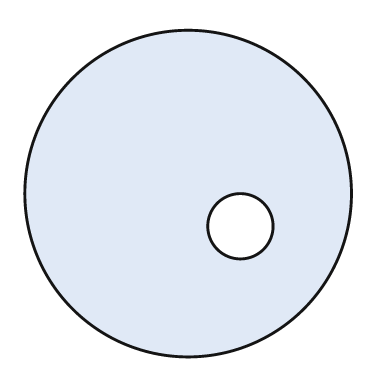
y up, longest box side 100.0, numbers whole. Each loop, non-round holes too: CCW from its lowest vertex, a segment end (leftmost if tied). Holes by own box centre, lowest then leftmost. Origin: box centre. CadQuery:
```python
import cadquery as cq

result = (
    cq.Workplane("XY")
    .moveTo(0.0, 0.0)
    .circle(50.0)
    .moveTo(16.0, -10.0)
    .circle(10.0)
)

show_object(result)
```